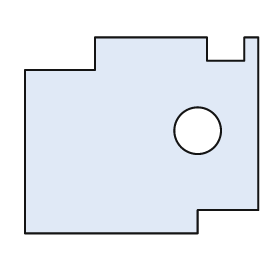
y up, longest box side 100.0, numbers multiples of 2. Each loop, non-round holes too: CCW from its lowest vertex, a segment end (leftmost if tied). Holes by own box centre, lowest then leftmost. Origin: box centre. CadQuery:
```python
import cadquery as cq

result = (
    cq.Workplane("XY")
    .moveTo(-50.0, -42.0)
    .lineTo(24.0, -42.0)
    .lineTo(24.0, -32.0)
    .lineTo(50.0, -32.0)
    .lineTo(50.0, 42.0)
    .lineTo(44.0, 42.0)
    .lineTo(44.0, 32.0)
    .lineTo(28.0, 32.0)
    .lineTo(28.0, 42.0)
    .lineTo(-20.0, 42.0)
    .lineTo(-20.0, 28.0)
    .lineTo(-50.0, 28.0)
    .close()
    .moveTo(24.0, 2.0)
    .circle(10.0)
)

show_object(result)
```